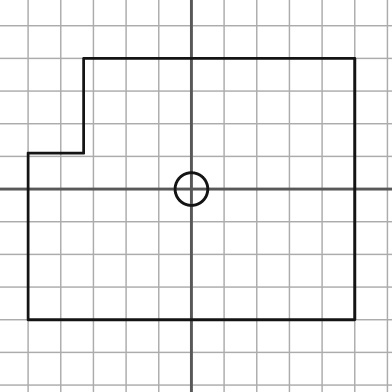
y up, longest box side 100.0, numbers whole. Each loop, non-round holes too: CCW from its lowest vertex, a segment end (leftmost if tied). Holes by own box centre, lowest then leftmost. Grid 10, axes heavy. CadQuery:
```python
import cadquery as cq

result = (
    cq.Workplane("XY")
    .moveTo(-50.0, -40.0)
    .lineTo(50.0, -40.0)
    .lineTo(50.0, 40.0)
    .lineTo(-33.0, 40.0)
    .lineTo(-33.0, 11.0)
    .lineTo(-50.0, 11.0)
    .close()
    .moveTo(0.0, 0.0)
    .circle(5.0)
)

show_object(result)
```